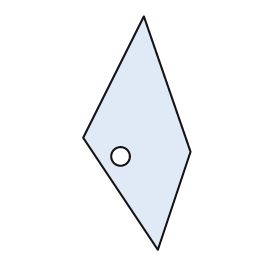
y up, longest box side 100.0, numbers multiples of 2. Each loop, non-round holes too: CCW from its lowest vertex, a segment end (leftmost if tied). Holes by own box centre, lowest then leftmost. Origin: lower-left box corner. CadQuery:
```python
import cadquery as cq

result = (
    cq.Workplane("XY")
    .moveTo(32.0, 0.0)
    .lineTo(46.0, 42.0)
    .lineTo(26.0, 100.0)
    .lineTo(0.0, 48.0)
    .close()
    .moveTo(16.0, 40.0)
    .circle(4.0)
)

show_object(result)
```